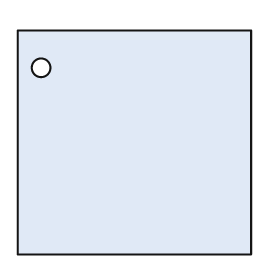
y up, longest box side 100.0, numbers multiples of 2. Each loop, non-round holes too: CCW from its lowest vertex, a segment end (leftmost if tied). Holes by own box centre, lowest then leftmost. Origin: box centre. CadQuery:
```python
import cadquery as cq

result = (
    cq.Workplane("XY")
    .moveTo(-50.0, -48.0)
    .lineTo(50.0, -48.0)
    .lineTo(50.0, 48.0)
    .lineTo(-50.0, 48.0)
    .close()
    .moveTo(-40.0, 32.0)
    .circle(4.0)
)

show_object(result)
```